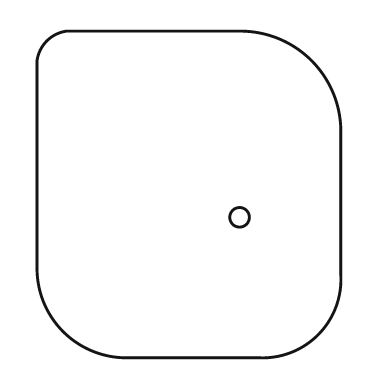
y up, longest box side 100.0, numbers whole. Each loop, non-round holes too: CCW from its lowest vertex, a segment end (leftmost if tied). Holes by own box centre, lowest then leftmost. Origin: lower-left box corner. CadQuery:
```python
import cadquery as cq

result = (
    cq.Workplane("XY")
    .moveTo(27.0, 0.0)
    .lineTo(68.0, 0.0)
    .threePointArc((86.0, 7.0), (93.0, 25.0))
    .lineTo(93.0, 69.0)
    .threePointArc((84.0, 91.0), (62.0, 100.0))
    .lineTo(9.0, 100.0)
    .threePointArc((3.0, 97.0), (0.0, 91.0))
    .lineTo(0.0, 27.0)
    .threePointArc((8.0, 8.0), (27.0, 0.0))
    .close()
    .moveTo(62.0, 43.0)
    .circle(3.0)
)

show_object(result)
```